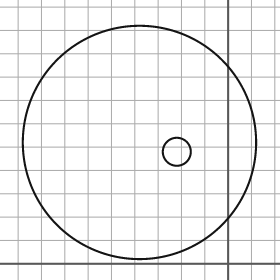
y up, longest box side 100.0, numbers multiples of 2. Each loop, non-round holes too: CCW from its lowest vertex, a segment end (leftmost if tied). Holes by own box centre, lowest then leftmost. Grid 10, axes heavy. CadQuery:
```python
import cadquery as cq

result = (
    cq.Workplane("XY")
    .moveTo(-38.0, 52.0)
    .circle(50.0)
    .moveTo(-22.0, 48.0)
    .circle(6.0)
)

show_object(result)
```